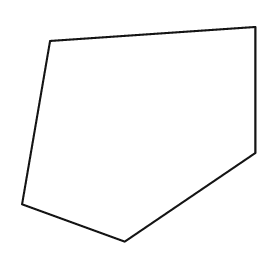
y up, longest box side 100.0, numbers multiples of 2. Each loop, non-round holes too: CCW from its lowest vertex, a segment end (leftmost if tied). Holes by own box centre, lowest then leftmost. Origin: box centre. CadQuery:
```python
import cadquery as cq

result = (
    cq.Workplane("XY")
    .moveTo(-6.0, -46.0)
    .lineTo(50.0, -8.0)
    .lineTo(50.0, 46.0)
    .lineTo(-38.0, 40.0)
    .lineTo(-50.0, -30.0)
    .close()
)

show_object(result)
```